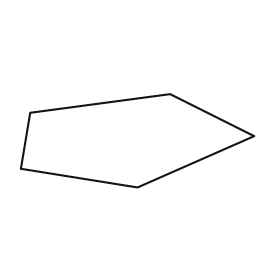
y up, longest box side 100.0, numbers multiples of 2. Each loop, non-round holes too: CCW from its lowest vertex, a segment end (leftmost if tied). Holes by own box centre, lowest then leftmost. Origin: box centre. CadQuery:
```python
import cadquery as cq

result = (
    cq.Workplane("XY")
    .moveTo(0.0, -20.0)
    .lineTo(50.0, 2.0)
    .lineTo(14.0, 20.0)
    .lineTo(-46.0, 12.0)
    .lineTo(-50.0, -12.0)
    .close()
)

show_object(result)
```